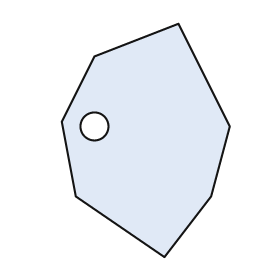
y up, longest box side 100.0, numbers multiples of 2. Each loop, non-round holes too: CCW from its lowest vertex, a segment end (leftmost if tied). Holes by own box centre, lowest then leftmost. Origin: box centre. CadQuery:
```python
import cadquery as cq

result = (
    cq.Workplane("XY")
    .moveTo(8.0, -50.0)
    .lineTo(28.0, -24.0)
    .lineTo(36.0, 6.0)
    .lineTo(14.0, 50.0)
    .lineTo(-22.0, 36.0)
    .lineTo(-36.0, 8.0)
    .lineTo(-30.0, -24.0)
    .close()
    .moveTo(-22.0, 6.0)
    .circle(6.0)
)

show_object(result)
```